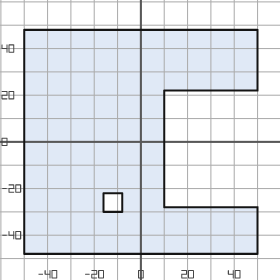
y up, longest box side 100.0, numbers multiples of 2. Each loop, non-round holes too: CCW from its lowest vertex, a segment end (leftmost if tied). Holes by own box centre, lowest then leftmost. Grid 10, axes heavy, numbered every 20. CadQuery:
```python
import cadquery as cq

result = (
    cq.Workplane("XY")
    .moveTo(-50.0, -48.0)
    .lineTo(50.0, -48.0)
    .lineTo(50.0, -28.0)
    .lineTo(10.0, -28.0)
    .lineTo(10.0, 22.0)
    .lineTo(50.0, 22.0)
    .lineTo(50.0, 48.0)
    .lineTo(-50.0, 48.0)
    .close()
    .moveTo(-16.0, -30.0)
    .lineTo(-8.0, -30.0)
    .lineTo(-8.0, -22.0)
    .lineTo(-16.0, -22.0)
    .close()
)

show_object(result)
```